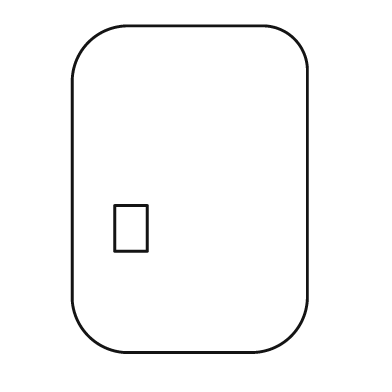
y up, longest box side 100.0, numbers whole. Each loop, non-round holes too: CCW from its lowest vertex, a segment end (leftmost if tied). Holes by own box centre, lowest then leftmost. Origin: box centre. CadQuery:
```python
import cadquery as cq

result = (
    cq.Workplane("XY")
    .moveTo(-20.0, -50.0)
    .lineTo(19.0, -50.0)
    .threePointArc((31.0, -45.0), (36.0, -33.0))
    .lineTo(36.0, 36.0)
    .threePointArc((32.0, 46.0), (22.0, 50.0))
    .lineTo(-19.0, 50.0)
    .threePointArc((-31.0, 45.0), (-36.0, 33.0))
    .lineTo(-36.0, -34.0)
    .threePointArc((-31.0, -45.0), (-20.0, -50.0))
    .close()
    .moveTo(-23.0, -19.0)
    .lineTo(-13.0, -19.0)
    .lineTo(-13.0, -5.0)
    .lineTo(-23.0, -5.0)
    .close()
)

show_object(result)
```